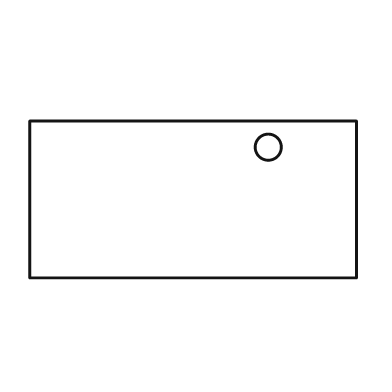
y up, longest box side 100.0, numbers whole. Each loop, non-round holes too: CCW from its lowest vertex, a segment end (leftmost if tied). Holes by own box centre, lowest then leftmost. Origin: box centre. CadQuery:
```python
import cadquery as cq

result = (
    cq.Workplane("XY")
    .moveTo(-50.0, -24.0)
    .lineTo(50.0, -24.0)
    .lineTo(50.0, 24.0)
    .lineTo(-50.0, 24.0)
    .close()
    .moveTo(23.0, 16.0)
    .circle(4.0)
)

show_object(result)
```